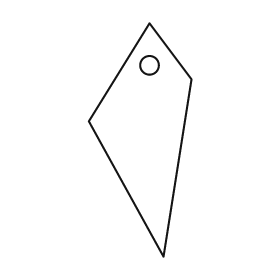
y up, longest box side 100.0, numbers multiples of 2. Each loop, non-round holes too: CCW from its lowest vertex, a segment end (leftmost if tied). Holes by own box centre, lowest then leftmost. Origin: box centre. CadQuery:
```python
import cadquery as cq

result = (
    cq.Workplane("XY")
    .moveTo(10.0, -50.0)
    .lineTo(22.0, 26.0)
    .lineTo(4.0, 50.0)
    .lineTo(-22.0, 8.0)
    .close()
    .moveTo(4.0, 32.0)
    .circle(4.0)
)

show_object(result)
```